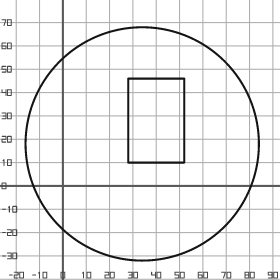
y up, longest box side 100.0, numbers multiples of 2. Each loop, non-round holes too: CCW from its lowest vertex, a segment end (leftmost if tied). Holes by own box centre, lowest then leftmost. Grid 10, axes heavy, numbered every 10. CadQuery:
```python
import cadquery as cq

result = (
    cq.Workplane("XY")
    .moveTo(34.0, 18.0)
    .circle(50.0)
    .moveTo(28.0, 10.0)
    .lineTo(52.0, 10.0)
    .lineTo(52.0, 46.0)
    .lineTo(28.0, 46.0)
    .close()
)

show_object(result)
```